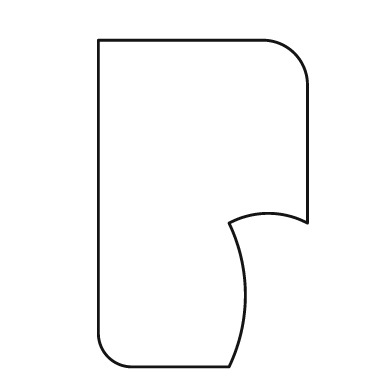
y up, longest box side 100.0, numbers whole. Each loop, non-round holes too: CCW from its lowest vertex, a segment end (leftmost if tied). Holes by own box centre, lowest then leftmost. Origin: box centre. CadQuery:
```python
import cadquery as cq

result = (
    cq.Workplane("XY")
    .moveTo(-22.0, -50.0)
    .lineTo(8.0, -50.0)
    .threePointArc((13.0, -28.0), (8.0, -6.0))
    .threePointArc((20.0, -3.0), (32.0, -6.0))
    .lineTo(32.0, 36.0)
    .threePointArc((28.0, 46.0), (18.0, 50.0))
    .lineTo(-32.0, 50.0)
    .lineTo(-32.0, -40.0)
    .threePointArc((-29.0, -47.0), (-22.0, -50.0))
    .close()
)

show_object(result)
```